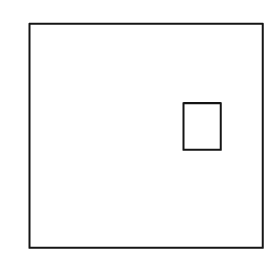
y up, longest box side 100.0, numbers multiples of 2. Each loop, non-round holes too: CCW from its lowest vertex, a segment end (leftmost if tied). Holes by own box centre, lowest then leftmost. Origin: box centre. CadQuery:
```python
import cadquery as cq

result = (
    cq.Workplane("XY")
    .moveTo(-50.0, -48.0)
    .lineTo(50.0, -48.0)
    .lineTo(50.0, 48.0)
    .lineTo(-50.0, 48.0)
    .close()
    .moveTo(16.0, -6.0)
    .lineTo(32.0, -6.0)
    .lineTo(32.0, 14.0)
    .lineTo(16.0, 14.0)
    .close()
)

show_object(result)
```